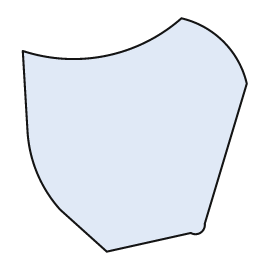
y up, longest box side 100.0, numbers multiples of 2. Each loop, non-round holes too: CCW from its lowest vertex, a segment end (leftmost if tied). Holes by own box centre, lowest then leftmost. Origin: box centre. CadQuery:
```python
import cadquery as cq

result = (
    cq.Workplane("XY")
    .moveTo(-12.0, -50.0)
    .lineTo(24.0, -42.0)
    .threePointArc((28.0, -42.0), (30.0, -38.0))
    .lineTo(48.0, 22.0)
    .threePointArc((38.0, 40.0), (20.0, 50.0))
    .threePointArc((-12.0, 34.0), (-48.0, 36.0))
    .lineTo(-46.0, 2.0)
    .threePointArc((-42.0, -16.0), (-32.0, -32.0))
    .close()
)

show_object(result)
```